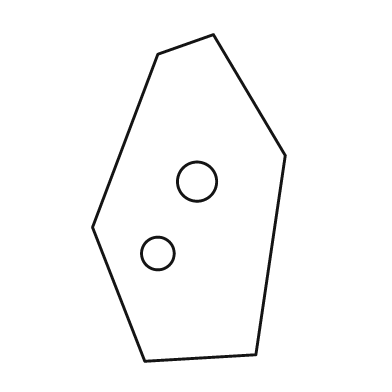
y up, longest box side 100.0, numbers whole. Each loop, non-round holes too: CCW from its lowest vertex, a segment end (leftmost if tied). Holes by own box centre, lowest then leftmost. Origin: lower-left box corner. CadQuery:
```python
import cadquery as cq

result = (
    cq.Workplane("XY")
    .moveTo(16.0, 0.0)
    .lineTo(50.0, 2.0)
    .lineTo(59.0, 63.0)
    .lineTo(37.0, 100.0)
    .lineTo(20.0, 94.0)
    .lineTo(0.0, 41.0)
    .close()
    .moveTo(20.0, 33.0)
    .circle(5.0)
    .moveTo(32.0, 55.0)
    .circle(6.0)
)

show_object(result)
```